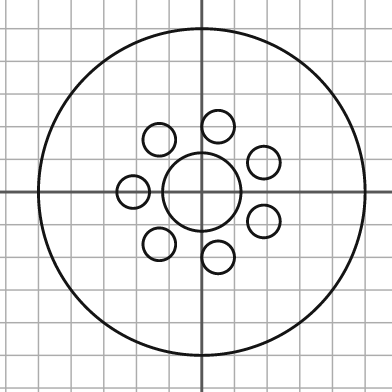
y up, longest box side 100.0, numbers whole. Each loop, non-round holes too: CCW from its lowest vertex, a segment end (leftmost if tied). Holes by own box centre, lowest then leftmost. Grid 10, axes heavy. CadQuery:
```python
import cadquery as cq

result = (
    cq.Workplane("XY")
    .moveTo(0.0, 0.0)
    .circle(50.0)
    .moveTo(5.0, -20.0)
    .circle(5.0)
    .moveTo(-13.0, -16.0)
    .circle(5.0)
    .moveTo(19.0, -9.0)
    .circle(5.0)
    .moveTo(-21.0, 0.0)
    .circle(5.0)
    .moveTo(0.0, 0.0)
    .circle(12.0)
    .moveTo(19.0, 9.0)
    .circle(5.0)
    .moveTo(-13.0, 16.0)
    .circle(5.0)
    .moveTo(5.0, 20.0)
    .circle(5.0)
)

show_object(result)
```